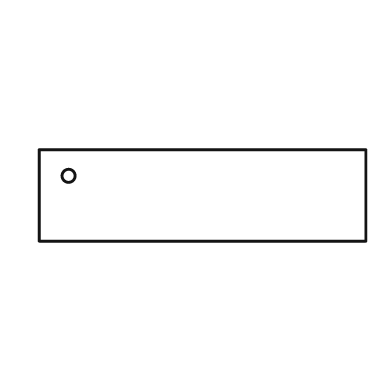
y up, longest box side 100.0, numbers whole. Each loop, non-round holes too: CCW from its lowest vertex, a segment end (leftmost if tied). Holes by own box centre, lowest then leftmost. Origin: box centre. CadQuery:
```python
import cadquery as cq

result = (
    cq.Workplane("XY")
    .moveTo(-50.0, -14.0)
    .lineTo(50.0, -14.0)
    .lineTo(50.0, 14.0)
    .lineTo(-50.0, 14.0)
    .close()
    .moveTo(-41.0, 6.0)
    .circle(2.0)
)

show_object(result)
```